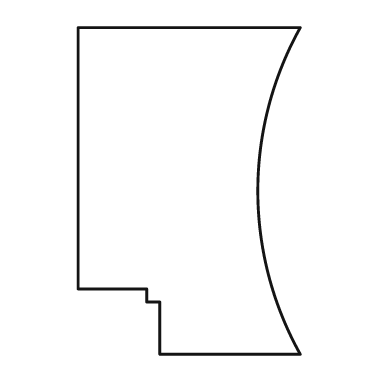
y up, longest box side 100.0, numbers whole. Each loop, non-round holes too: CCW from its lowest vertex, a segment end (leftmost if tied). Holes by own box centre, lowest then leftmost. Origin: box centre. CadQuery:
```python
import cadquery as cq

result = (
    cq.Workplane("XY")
    .moveTo(-9.0, -50.0)
    .lineTo(34.0, -50.0)
    .threePointArc((21.0, 0.0), (34.0, 50.0))
    .lineTo(-34.0, 50.0)
    .lineTo(-34.0, -30.0)
    .lineTo(-13.0, -30.0)
    .lineTo(-13.0, -34.0)
    .lineTo(-9.0, -34.0)
    .close()
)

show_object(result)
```